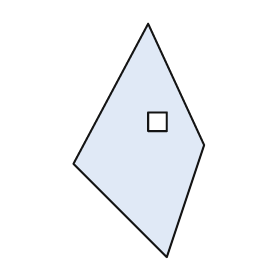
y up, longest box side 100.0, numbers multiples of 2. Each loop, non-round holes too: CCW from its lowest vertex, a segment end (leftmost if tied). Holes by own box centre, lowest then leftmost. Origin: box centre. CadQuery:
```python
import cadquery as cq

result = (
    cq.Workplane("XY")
    .moveTo(12.0, -50.0)
    .lineTo(28.0, -2.0)
    .lineTo(4.0, 50.0)
    .lineTo(-28.0, -10.0)
    .close()
    .moveTo(4.0, 4.0)
    .lineTo(12.0, 4.0)
    .lineTo(12.0, 12.0)
    .lineTo(4.0, 12.0)
    .close()
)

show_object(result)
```